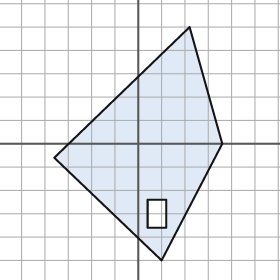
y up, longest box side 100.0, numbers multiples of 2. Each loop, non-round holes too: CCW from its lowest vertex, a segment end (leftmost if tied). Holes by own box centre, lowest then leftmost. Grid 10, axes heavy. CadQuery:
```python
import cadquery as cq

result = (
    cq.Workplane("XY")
    .moveTo(10.0, -50.0)
    .lineTo(36.0, 0.0)
    .lineTo(22.0, 50.0)
    .lineTo(-36.0, -6.0)
    .close()
    .moveTo(4.0, -36.0)
    .lineTo(12.0, -36.0)
    .lineTo(12.0, -24.0)
    .lineTo(4.0, -24.0)
    .close()
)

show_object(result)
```